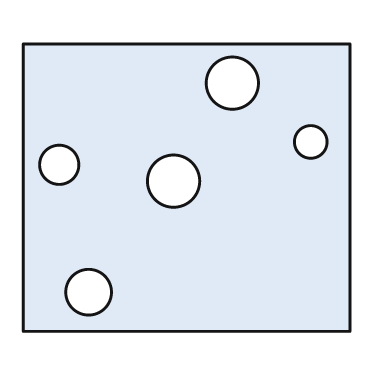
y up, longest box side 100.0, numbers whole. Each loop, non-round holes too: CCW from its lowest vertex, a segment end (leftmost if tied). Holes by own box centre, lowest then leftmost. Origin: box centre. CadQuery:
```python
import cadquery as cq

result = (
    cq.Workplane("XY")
    .moveTo(-50.0, -44.0)
    .lineTo(50.0, -44.0)
    .lineTo(50.0, 44.0)
    .lineTo(-50.0, 44.0)
    .close()
    .moveTo(-30.0, -32.0)
    .circle(7.0)
    .moveTo(-4.0, 2.0)
    .circle(8.0)
    .moveTo(-39.0, 7.0)
    .circle(6.0)
    .moveTo(38.0, 14.0)
    .circle(5.0)
    .moveTo(14.0, 32.0)
    .circle(8.0)
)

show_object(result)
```